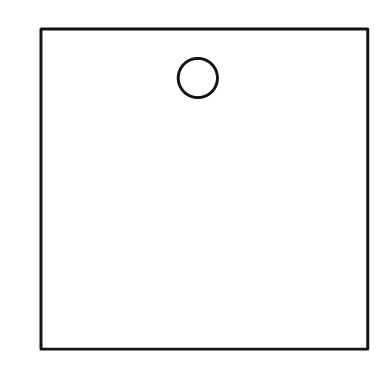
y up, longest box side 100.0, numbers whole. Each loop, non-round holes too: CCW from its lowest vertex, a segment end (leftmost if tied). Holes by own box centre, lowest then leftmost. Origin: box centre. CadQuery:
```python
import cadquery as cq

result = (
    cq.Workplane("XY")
    .moveTo(-50.0, -49.0)
    .lineTo(50.0, -49.0)
    .lineTo(50.0, 49.0)
    .lineTo(-50.0, 49.0)
    .close()
    .moveTo(-2.0, 34.0)
    .circle(6.0)
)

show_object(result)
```